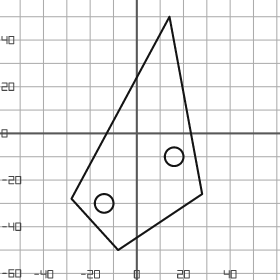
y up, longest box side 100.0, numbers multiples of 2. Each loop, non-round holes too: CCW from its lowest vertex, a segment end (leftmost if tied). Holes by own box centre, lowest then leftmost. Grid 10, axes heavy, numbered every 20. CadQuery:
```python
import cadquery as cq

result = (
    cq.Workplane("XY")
    .moveTo(-8.0, -50.0)
    .lineTo(28.0, -26.0)
    .lineTo(14.0, 50.0)
    .lineTo(-28.0, -28.0)
    .close()
    .moveTo(-14.0, -30.0)
    .circle(4.0)
    .moveTo(16.0, -10.0)
    .circle(4.0)
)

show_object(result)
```